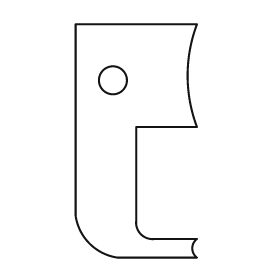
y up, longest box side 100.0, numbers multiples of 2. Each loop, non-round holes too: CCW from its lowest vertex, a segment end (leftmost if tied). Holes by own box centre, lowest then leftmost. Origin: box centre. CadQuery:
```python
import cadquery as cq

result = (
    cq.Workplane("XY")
    .moveTo(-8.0, -50.0)
    .lineTo(26.0, -50.0)
    .threePointArc((24.0, -46.0), (26.0, -42.0))
    .lineTo(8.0, -42.0)
    .threePointArc((2.0, -40.0), (0.0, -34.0))
    .lineTo(0.0, 6.0)
    .lineTo(26.0, 6.0)
    .threePointArc((22.0, 28.0), (26.0, 50.0))
    .lineTo(-26.0, 50.0)
    .lineTo(-26.0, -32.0)
    .threePointArc((-20.0, -44.0), (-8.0, -50.0))
    .close()
    .moveTo(-10.0, 26.0)
    .circle(6.0)
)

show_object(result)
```